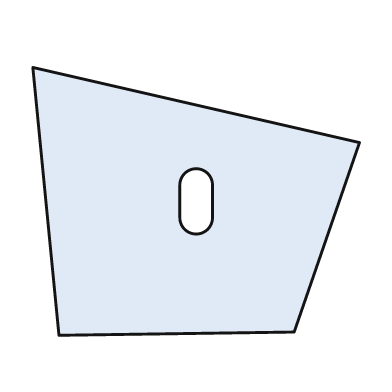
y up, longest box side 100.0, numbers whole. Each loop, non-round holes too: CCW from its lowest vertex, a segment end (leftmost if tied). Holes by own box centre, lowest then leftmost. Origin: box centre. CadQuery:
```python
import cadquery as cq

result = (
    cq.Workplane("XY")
    .moveTo(-42.0, -41.0)
    .lineTo(30.0, -40.0)
    .lineTo(50.0, 18.0)
    .lineTo(-50.0, 41.0)
    .close()
    .moveTo(-5.0, -5.0)
    .threePointArc((0.0, -10.0), (5.0, -5.0))
    .lineTo(5.0, 5.0)
    .threePointArc((0.0, 10.0), (-5.0, 5.0))
    .close()
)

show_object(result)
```